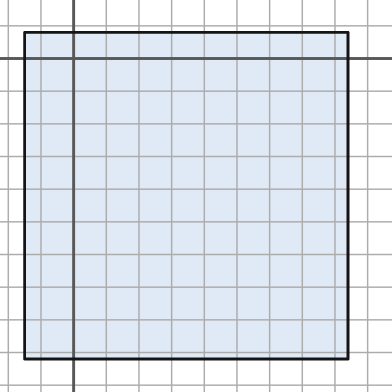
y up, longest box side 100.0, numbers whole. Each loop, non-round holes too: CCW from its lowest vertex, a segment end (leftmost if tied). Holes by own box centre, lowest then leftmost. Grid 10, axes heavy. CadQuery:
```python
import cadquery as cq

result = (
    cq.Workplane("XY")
    .moveTo(-15.0, -92.0)
    .lineTo(84.0, -92.0)
    .lineTo(84.0, 8.0)
    .lineTo(-15.0, 8.0)
    .close()
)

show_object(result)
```